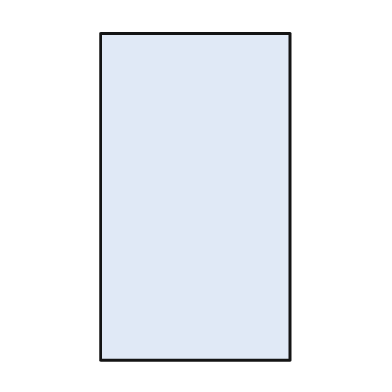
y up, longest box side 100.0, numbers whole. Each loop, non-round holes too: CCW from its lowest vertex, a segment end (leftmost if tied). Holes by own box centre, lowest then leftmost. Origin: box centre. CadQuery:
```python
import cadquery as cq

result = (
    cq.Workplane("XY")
    .moveTo(-29.0, -50.0)
    .lineTo(29.0, -50.0)
    .lineTo(29.0, 50.0)
    .lineTo(-29.0, 50.0)
    .close()
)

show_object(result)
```